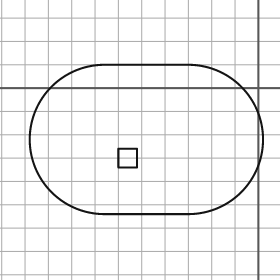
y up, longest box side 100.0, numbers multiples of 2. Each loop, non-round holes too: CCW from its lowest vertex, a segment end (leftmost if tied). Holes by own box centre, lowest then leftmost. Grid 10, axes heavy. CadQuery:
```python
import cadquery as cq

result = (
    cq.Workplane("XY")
    .moveTo(-66.0, -54.0)
    .lineTo(-30.0, -54.0)
    .threePointArc((2.0, -22.0), (-30.0, 10.0))
    .lineTo(-66.0, 10.0)
    .threePointArc((-98.0, -22.0), (-66.0, -54.0))
    .close()
    .moveTo(-60.0, -34.0)
    .lineTo(-52.0, -34.0)
    .lineTo(-52.0, -26.0)
    .lineTo(-60.0, -26.0)
    .close()
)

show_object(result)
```